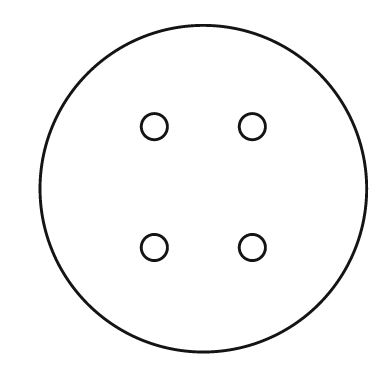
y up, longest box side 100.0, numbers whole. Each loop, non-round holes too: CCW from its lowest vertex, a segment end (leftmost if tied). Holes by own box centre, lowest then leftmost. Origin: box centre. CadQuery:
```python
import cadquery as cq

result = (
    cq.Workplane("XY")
    .moveTo(0.0, 0.0)
    .circle(50.0)
    .moveTo(-15.0, -18.0)
    .circle(4.0)
    .moveTo(15.0, -18.0)
    .circle(4.0)
    .moveTo(-15.0, 19.0)
    .circle(4.0)
    .moveTo(15.0, 19.0)
    .circle(4.0)
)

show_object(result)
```